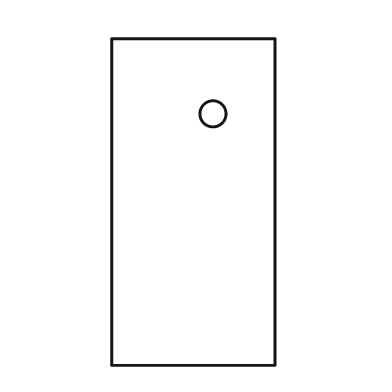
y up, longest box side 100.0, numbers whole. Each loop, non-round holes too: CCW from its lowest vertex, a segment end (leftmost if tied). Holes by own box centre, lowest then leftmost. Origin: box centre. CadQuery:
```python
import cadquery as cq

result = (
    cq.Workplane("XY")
    .moveTo(-25.0, -50.0)
    .lineTo(25.0, -50.0)
    .lineTo(25.0, 50.0)
    .lineTo(-25.0, 50.0)
    .close()
    .moveTo(6.0, 27.0)
    .circle(4.0)
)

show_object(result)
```